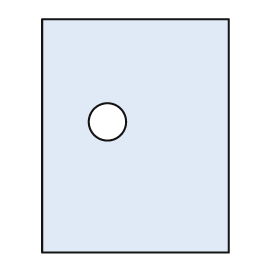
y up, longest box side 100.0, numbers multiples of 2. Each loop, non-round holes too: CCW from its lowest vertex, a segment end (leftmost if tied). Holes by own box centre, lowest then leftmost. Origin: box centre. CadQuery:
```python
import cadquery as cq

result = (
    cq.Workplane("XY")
    .moveTo(-40.0, -50.0)
    .lineTo(40.0, -50.0)
    .lineTo(40.0, 50.0)
    .lineTo(-40.0, 50.0)
    .close()
    .moveTo(-12.0, 6.0)
    .circle(8.0)
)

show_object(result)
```